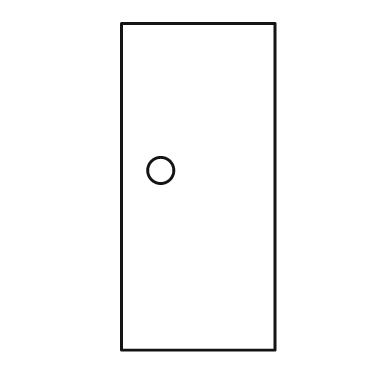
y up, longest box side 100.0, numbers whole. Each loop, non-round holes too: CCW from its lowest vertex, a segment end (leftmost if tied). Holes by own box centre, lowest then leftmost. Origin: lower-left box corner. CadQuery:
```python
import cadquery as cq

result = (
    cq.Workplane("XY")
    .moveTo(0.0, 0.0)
    .lineTo(47.0, 0.0)
    .lineTo(47.0, 100.0)
    .lineTo(0.0, 100.0)
    .close()
    .moveTo(12.0, 55.0)
    .circle(4.0)
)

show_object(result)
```